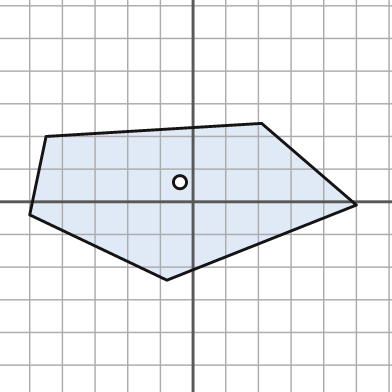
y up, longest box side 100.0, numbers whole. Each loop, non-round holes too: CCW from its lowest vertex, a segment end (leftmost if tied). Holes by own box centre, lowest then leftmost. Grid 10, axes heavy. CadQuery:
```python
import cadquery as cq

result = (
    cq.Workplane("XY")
    .moveTo(-8.0, -24.0)
    .lineTo(50.0, -1.0)
    .lineTo(21.0, 24.0)
    .lineTo(-45.0, 20.0)
    .lineTo(-50.0, -4.0)
    .close()
    .moveTo(-4.0, 6.0)
    .circle(2.0)
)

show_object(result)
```